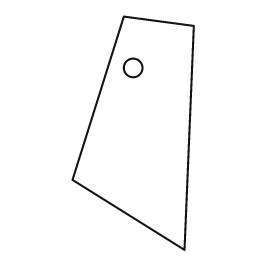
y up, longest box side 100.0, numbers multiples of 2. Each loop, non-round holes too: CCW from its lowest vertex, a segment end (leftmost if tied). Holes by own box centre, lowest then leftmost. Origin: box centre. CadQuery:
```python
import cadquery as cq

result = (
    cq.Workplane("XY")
    .moveTo(22.0, -50.0)
    .lineTo(26.0, 46.0)
    .lineTo(-4.0, 50.0)
    .lineTo(-26.0, -20.0)
    .close()
    .moveTo(0.0, 28.0)
    .circle(4.0)
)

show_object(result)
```